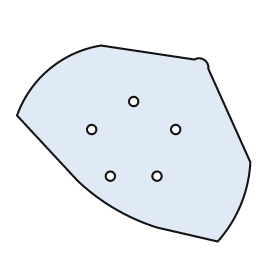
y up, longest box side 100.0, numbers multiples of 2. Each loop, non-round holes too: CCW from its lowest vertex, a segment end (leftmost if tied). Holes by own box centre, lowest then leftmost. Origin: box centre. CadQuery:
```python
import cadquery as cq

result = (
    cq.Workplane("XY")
    .moveTo(36.0, -42.0)
    .threePointArc((46.0, -26.0), (50.0, -8.0))
    .lineTo(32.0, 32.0)
    .threePointArc((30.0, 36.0), (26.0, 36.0))
    .lineTo(-14.0, 42.0)
    .threePointArc((-36.0, 32.0), (-50.0, 12.0))
    .lineTo(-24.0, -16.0)
    .threePointArc((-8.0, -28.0), (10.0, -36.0))
    .close()
    .moveTo(-10.0, -14.0)
    .circle(2.0)
    .moveTo(10.0, -14.0)
    .circle(2.0)
    .moveTo(-18.0, 6.0)
    .circle(2.0)
    .moveTo(18.0, 6.0)
    .circle(2.0)
    .moveTo(0.0, 18.0)
    .circle(2.0)
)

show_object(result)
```